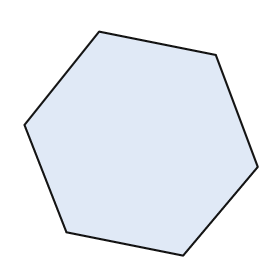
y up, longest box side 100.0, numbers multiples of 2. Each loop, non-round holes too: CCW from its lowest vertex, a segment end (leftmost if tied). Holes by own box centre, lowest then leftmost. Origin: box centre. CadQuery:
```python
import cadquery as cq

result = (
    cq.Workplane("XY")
    .moveTo(18.0, -48.0)
    .lineTo(50.0, -10.0)
    .lineTo(32.0, 38.0)
    .lineTo(-18.0, 48.0)
    .lineTo(-50.0, 8.0)
    .lineTo(-32.0, -38.0)
    .close()
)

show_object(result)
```